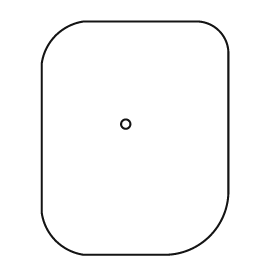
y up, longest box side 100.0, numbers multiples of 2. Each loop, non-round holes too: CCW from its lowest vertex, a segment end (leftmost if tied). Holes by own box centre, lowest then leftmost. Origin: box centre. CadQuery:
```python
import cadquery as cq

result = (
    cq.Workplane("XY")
    .moveTo(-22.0, -50.0)
    .lineTo(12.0, -50.0)
    .threePointArc((32.0, -42.0), (40.0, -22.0))
    .lineTo(40.0, 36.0)
    .threePointArc((36.0, 46.0), (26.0, 50.0))
    .lineTo(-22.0, 50.0)
    .threePointArc((-34.0, 44.0), (-40.0, 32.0))
    .lineTo(-40.0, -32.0)
    .threePointArc((-34.0, -44.0), (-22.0, -50.0))
    .close()
    .moveTo(-4.0, 6.0)
    .circle(2.0)
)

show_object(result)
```